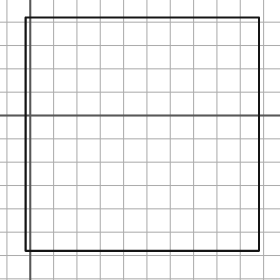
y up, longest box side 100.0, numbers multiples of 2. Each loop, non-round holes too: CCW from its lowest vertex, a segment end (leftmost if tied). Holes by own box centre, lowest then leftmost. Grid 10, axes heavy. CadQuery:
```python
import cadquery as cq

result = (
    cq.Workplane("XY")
    .moveTo(-2.0, -58.0)
    .lineTo(98.0, -58.0)
    .lineTo(98.0, 42.0)
    .lineTo(-2.0, 42.0)
    .close()
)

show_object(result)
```